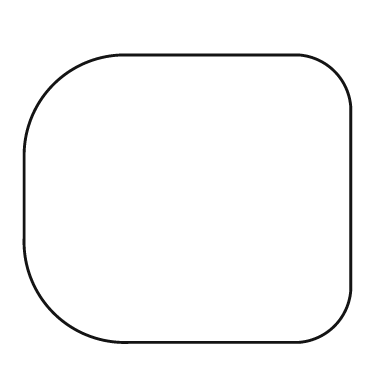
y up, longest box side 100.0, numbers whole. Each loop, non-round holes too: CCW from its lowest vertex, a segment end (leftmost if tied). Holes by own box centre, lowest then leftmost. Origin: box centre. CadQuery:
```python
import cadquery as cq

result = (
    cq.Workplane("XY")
    .moveTo(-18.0, -44.0)
    .lineTo(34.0, -44.0)
    .threePointArc((45.0, -39.0), (50.0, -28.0))
    .lineTo(50.0, 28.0)
    .threePointArc((45.0, 39.0), (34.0, 44.0))
    .lineTo(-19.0, 44.0)
    .threePointArc((-41.0, 35.0), (-50.0, 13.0))
    .lineTo(-50.0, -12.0)
    .threePointArc((-41.0, -35.0), (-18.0, -44.0))
    .close()
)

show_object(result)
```